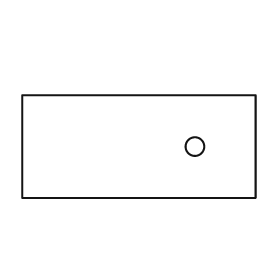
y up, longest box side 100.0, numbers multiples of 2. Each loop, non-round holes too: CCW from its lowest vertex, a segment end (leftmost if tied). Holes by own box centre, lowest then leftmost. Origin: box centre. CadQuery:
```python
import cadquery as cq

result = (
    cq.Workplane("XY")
    .moveTo(-50.0, -22.0)
    .lineTo(50.0, -22.0)
    .lineTo(50.0, 22.0)
    .lineTo(-50.0, 22.0)
    .close()
    .moveTo(24.0, 0.0)
    .circle(4.0)
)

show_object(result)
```